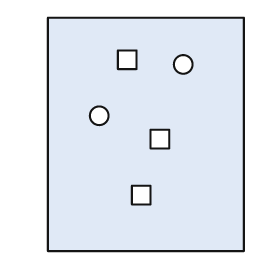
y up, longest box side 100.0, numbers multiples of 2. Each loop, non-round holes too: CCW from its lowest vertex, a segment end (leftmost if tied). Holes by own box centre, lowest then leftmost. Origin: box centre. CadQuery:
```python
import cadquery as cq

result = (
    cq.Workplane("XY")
    .moveTo(-42.0, -50.0)
    .lineTo(42.0, -50.0)
    .lineTo(42.0, 50.0)
    .lineTo(-42.0, 50.0)
    .close()
    .moveTo(-6.0, -30.0)
    .lineTo(2.0, -30.0)
    .lineTo(2.0, -22.0)
    .lineTo(-6.0, -22.0)
    .close()
    .moveTo(2.0, -6.0)
    .lineTo(10.0, -6.0)
    .lineTo(10.0, 2.0)
    .lineTo(2.0, 2.0)
    .close()
    .moveTo(-20.0, 8.0)
    .circle(4.0)
    .moveTo(16.0, 30.0)
    .circle(4.0)
    .moveTo(-12.0, 28.0)
    .lineTo(-4.0, 28.0)
    .lineTo(-4.0, 36.0)
    .lineTo(-12.0, 36.0)
    .close()
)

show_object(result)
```